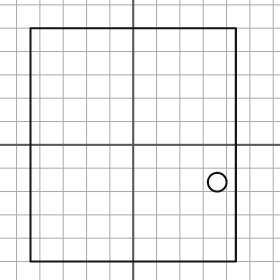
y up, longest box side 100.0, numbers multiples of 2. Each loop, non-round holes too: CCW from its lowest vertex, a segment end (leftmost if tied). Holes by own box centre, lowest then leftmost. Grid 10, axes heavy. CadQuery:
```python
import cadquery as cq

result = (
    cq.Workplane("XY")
    .moveTo(-44.0, -50.0)
    .lineTo(44.0, -50.0)
    .lineTo(44.0, 50.0)
    .lineTo(-44.0, 50.0)
    .close()
    .moveTo(36.0, -16.0)
    .circle(4.0)
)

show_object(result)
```